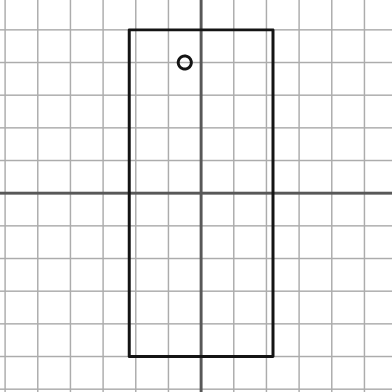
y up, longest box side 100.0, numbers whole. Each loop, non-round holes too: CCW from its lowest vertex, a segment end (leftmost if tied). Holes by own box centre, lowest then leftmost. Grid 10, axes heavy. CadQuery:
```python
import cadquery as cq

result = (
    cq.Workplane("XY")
    .moveTo(-22.0, -50.0)
    .lineTo(22.0, -50.0)
    .lineTo(22.0, 50.0)
    .lineTo(-22.0, 50.0)
    .close()
    .moveTo(-5.0, 40.0)
    .circle(2.0)
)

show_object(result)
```